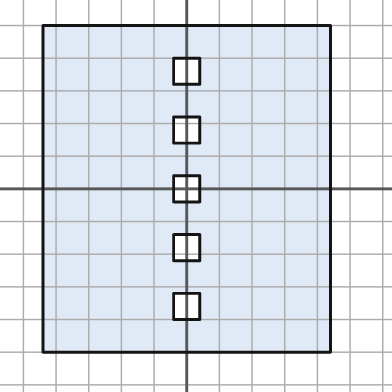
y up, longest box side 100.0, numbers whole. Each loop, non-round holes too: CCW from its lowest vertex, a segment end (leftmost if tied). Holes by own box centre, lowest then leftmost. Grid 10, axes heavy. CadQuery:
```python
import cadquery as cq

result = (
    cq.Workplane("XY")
    .moveTo(-44.0, -50.0)
    .lineTo(44.0, -50.0)
    .lineTo(44.0, 50.0)
    .lineTo(-44.0, 50.0)
    .close()
    .moveTo(-4.0, -40.0)
    .lineTo(4.0, -40.0)
    .lineTo(4.0, -32.0)
    .lineTo(-4.0, -32.0)
    .close()
    .moveTo(-4.0, -22.0)
    .lineTo(4.0, -22.0)
    .lineTo(4.0, -14.0)
    .lineTo(-4.0, -14.0)
    .close()
    .moveTo(-4.0, -4.0)
    .lineTo(4.0, -4.0)
    .lineTo(4.0, 4.0)
    .lineTo(-4.0, 4.0)
    .close()
    .moveTo(-4.0, 14.0)
    .lineTo(4.0, 14.0)
    .lineTo(4.0, 22.0)
    .lineTo(-4.0, 22.0)
    .close()
    .moveTo(-4.0, 32.0)
    .lineTo(4.0, 32.0)
    .lineTo(4.0, 40.0)
    .lineTo(-4.0, 40.0)
    .close()
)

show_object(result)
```